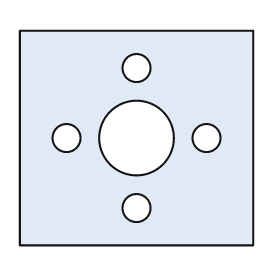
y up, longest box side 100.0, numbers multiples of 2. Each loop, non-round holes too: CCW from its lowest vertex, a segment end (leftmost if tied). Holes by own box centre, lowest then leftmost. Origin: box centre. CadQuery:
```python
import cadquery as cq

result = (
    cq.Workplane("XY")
    .moveTo(-50.0, -46.0)
    .lineTo(50.0, -46.0)
    .lineTo(50.0, 46.0)
    .lineTo(-50.0, 46.0)
    .close()
    .moveTo(0.0, -30.0)
    .circle(6.0)
    .moveTo(-30.0, 0.0)
    .circle(6.0)
    .moveTo(0.0, 0.0)
    .circle(16.0)
    .moveTo(30.0, 0.0)
    .circle(6.0)
    .moveTo(0.0, 30.0)
    .circle(6.0)
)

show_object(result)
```